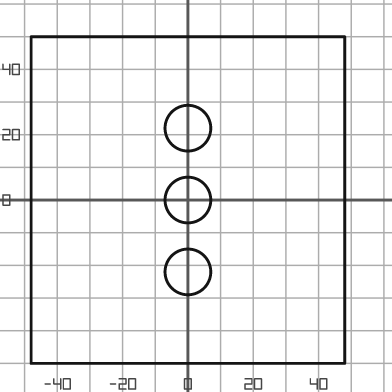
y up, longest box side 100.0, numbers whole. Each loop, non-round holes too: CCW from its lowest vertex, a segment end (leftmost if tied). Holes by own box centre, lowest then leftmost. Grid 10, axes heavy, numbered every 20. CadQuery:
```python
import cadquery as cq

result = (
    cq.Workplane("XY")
    .moveTo(-48.0, -50.0)
    .lineTo(48.0, -50.0)
    .lineTo(48.0, 50.0)
    .lineTo(-48.0, 50.0)
    .close()
    .moveTo(0.0, -22.0)
    .circle(7.0)
    .moveTo(0.0, 0.0)
    .circle(7.0)
    .moveTo(0.0, 22.0)
    .circle(7.0)
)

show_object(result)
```